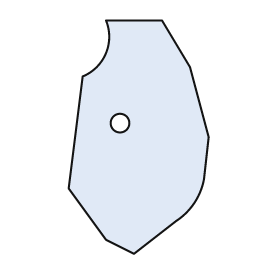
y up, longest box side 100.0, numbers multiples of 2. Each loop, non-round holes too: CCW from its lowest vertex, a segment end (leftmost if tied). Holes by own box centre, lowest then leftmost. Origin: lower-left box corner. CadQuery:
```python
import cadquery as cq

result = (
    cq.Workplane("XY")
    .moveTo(28.0, 0.0)
    .lineTo(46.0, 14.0)
    .threePointArc((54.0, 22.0), (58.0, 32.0))
    .lineTo(60.0, 50.0)
    .lineTo(52.0, 80.0)
    .lineTo(40.0, 100.0)
    .lineTo(16.0, 100.0)
    .threePointArc((16.0, 86.0), (6.0, 76.0))
    .lineTo(0.0, 28.0)
    .lineTo(16.0, 6.0)
    .close()
    .moveTo(22.0, 56.0)
    .circle(4.0)
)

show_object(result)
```